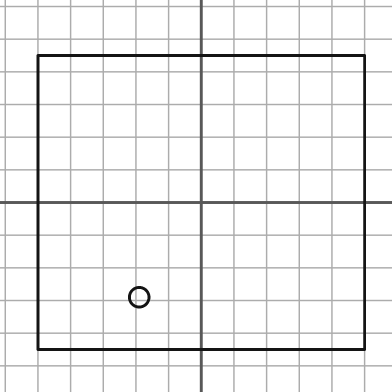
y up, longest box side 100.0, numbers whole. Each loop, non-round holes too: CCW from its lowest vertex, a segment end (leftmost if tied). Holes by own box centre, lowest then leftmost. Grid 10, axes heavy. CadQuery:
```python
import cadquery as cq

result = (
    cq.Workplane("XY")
    .moveTo(-50.0, -45.0)
    .lineTo(50.0, -45.0)
    .lineTo(50.0, 45.0)
    .lineTo(-50.0, 45.0)
    .close()
    .moveTo(-19.0, -29.0)
    .circle(3.0)
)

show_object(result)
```